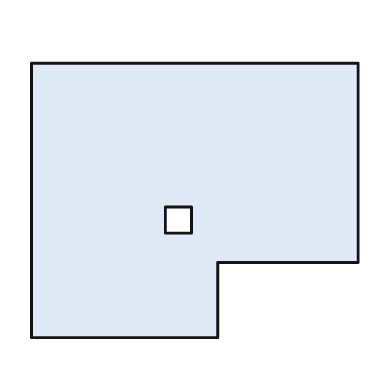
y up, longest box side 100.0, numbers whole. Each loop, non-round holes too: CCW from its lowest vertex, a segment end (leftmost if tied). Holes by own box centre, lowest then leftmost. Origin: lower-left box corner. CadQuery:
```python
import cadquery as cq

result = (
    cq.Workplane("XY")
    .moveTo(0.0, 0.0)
    .lineTo(57.0, 0.0)
    .lineTo(57.0, 23.0)
    .lineTo(100.0, 23.0)
    .lineTo(100.0, 84.0)
    .lineTo(0.0, 84.0)
    .close()
    .moveTo(41.0, 32.0)
    .lineTo(49.0, 32.0)
    .lineTo(49.0, 40.0)
    .lineTo(41.0, 40.0)
    .close()
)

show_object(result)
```